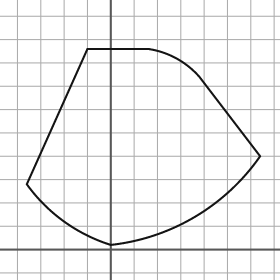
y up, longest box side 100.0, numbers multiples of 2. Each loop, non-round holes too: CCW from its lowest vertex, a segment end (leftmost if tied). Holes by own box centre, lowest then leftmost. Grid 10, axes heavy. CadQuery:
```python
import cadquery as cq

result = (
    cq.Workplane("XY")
    .moveTo(0.0, 2.0)
    .threePointArc((36.0, 14.0), (64.0, 40.0))
    .lineTo(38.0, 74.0)
    .threePointArc((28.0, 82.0), (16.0, 86.0))
    .lineTo(-10.0, 86.0)
    .lineTo(-36.0, 28.0)
    .threePointArc((-20.0, 12.0), (0.0, 2.0))
    .close()
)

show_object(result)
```